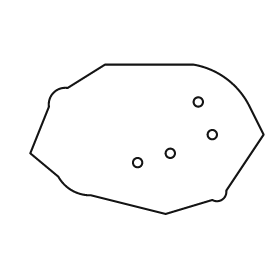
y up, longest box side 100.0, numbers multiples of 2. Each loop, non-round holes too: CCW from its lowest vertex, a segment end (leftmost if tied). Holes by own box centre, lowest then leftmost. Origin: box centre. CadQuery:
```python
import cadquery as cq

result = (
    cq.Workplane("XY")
    .moveTo(8.0, -32.0)
    .lineTo(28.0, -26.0)
    .threePointArc((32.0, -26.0), (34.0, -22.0))
    .lineTo(50.0, 2.0)
    .lineTo(44.0, 14.0)
    .threePointArc((34.0, 26.0), (20.0, 32.0))
    .lineTo(-18.0, 32.0)
    .lineTo(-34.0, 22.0)
    .threePointArc((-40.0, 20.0), (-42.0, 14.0))
    .lineTo(-50.0, -6.0)
    .lineTo(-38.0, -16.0)
    .threePointArc((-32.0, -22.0), (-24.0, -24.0))
    .close()
    .moveTo(-4.0, -10.0)
    .circle(2.0)
    .moveTo(10.0, -6.0)
    .circle(2.0)
    .moveTo(28.0, 2.0)
    .circle(2.0)
    .moveTo(22.0, 16.0)
    .circle(2.0)
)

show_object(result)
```